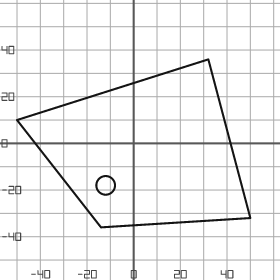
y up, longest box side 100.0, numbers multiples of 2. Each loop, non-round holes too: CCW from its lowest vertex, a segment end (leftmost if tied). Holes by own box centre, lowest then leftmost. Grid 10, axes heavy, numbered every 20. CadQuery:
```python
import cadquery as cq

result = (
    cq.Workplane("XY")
    .moveTo(-14.0, -36.0)
    .lineTo(50.0, -32.0)
    .lineTo(32.0, 36.0)
    .lineTo(-50.0, 10.0)
    .close()
    .moveTo(-12.0, -18.0)
    .circle(4.0)
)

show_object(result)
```